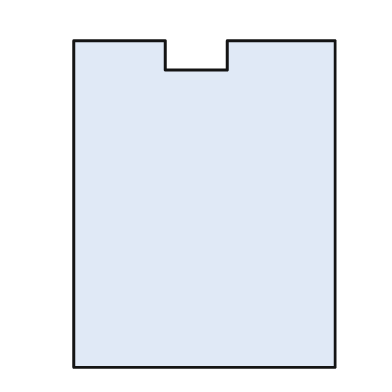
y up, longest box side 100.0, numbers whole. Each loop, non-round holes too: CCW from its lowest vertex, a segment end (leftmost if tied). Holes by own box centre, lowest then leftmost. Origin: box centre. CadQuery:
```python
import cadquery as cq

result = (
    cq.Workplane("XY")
    .moveTo(-40.0, -50.0)
    .lineTo(40.0, -50.0)
    .lineTo(40.0, 50.0)
    .lineTo(7.0, 50.0)
    .lineTo(7.0, 41.0)
    .lineTo(-12.0, 41.0)
    .lineTo(-12.0, 50.0)
    .lineTo(-40.0, 50.0)
    .close()
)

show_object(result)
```